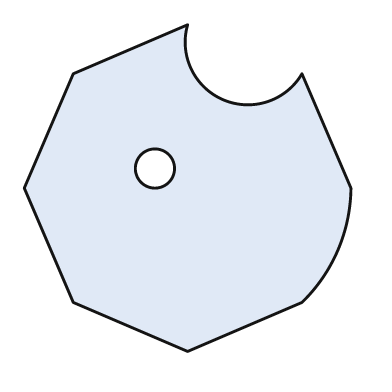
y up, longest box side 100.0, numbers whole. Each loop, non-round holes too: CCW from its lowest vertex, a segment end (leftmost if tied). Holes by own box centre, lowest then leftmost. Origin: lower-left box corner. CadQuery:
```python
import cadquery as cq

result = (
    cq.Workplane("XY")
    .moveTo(50.0, 0.0)
    .lineTo(85.0, 15.0)
    .threePointArc((96.0, 31.0), (100.0, 50.0))
    .lineTo(85.0, 85.0)
    .threePointArc((61.0, 77.0), (50.0, 100.0))
    .lineTo(15.0, 85.0)
    .lineTo(0.0, 50.0)
    .lineTo(15.0, 15.0)
    .close()
    .moveTo(40.0, 56.0)
    .circle(6.0)
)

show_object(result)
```